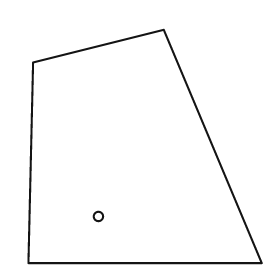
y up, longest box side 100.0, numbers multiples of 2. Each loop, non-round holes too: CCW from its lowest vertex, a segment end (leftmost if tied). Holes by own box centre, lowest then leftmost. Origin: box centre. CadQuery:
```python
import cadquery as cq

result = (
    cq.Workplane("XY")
    .moveTo(-50.0, -50.0)
    .lineTo(50.0, -50.0)
    .lineTo(8.0, 50.0)
    .lineTo(-48.0, 36.0)
    .close()
    .moveTo(-20.0, -30.0)
    .circle(2.0)
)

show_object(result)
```